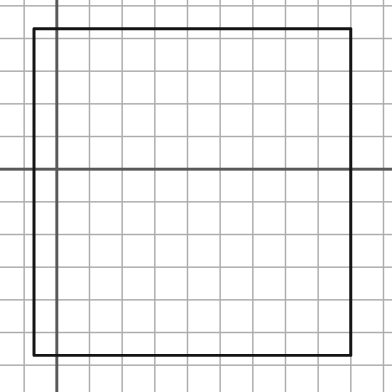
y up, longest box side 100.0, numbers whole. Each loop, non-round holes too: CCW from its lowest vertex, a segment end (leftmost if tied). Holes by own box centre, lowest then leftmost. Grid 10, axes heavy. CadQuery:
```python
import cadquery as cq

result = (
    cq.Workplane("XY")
    .moveTo(-7.0, -57.0)
    .lineTo(90.0, -57.0)
    .lineTo(90.0, 43.0)
    .lineTo(-7.0, 43.0)
    .close()
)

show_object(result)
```